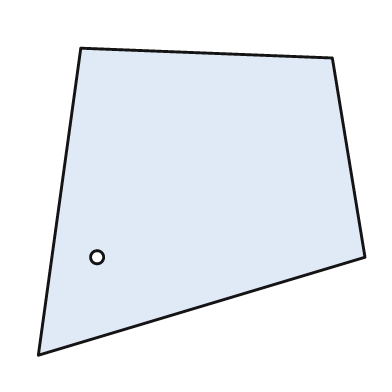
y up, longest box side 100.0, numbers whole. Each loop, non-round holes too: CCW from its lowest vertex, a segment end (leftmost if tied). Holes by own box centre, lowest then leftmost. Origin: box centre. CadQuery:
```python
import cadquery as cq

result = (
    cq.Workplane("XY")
    .moveTo(-50.0, -47.0)
    .lineTo(50.0, -17.0)
    .lineTo(40.0, 44.0)
    .lineTo(-37.0, 47.0)
    .close()
    .moveTo(-32.0, -17.0)
    .circle(2.0)
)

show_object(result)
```